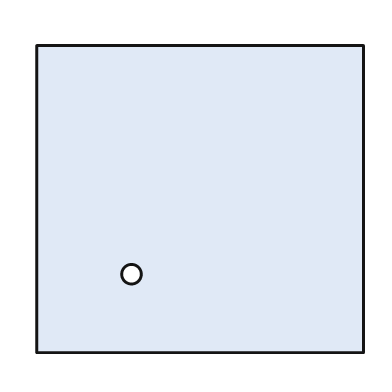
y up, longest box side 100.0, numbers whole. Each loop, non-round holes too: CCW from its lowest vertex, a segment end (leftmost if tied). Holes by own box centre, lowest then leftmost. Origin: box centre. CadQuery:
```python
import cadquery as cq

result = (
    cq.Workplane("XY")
    .moveTo(-50.0, -47.0)
    .lineTo(50.0, -47.0)
    .lineTo(50.0, 47.0)
    .lineTo(-50.0, 47.0)
    .close()
    .moveTo(-21.0, -23.0)
    .circle(3.0)
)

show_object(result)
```